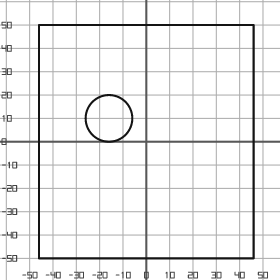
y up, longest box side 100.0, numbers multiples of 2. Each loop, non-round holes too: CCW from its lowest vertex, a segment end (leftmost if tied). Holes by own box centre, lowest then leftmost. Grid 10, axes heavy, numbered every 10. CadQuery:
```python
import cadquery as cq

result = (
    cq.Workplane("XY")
    .moveTo(-46.0, -50.0)
    .lineTo(46.0, -50.0)
    .lineTo(46.0, 50.0)
    .lineTo(-46.0, 50.0)
    .close()
    .moveTo(-16.0, 10.0)
    .circle(10.0)
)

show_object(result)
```